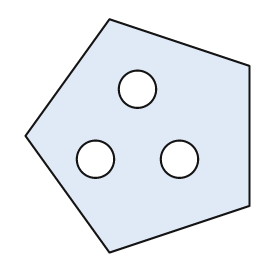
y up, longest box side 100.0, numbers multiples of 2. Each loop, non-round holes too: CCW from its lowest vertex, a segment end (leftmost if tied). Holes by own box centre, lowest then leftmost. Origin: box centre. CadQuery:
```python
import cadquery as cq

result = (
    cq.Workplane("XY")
    .moveTo(-12.0, -50.0)
    .lineTo(48.0, -30.0)
    .lineTo(48.0, 30.0)
    .lineTo(-12.0, 50.0)
    .lineTo(-48.0, 0.0)
    .close()
    .moveTo(-18.0, -10.0)
    .circle(8.0)
    .moveTo(18.0, -10.0)
    .circle(8.0)
    .moveTo(0.0, 20.0)
    .circle(8.0)
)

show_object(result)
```